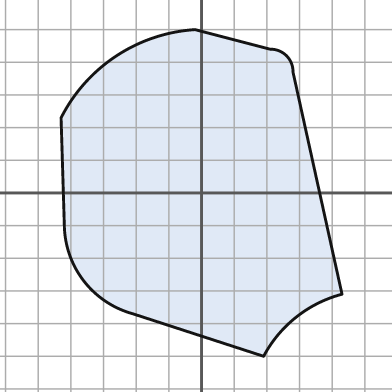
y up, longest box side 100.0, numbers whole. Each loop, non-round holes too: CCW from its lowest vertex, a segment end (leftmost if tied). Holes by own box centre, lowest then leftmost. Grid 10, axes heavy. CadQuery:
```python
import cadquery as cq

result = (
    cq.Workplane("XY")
    .moveTo(19.0, -50.0)
    .threePointArc((29.0, -38.0), (43.0, -31.0))
    .lineTo(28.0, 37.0)
    .threePointArc((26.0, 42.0), (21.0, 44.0))
    .lineTo(-2.0, 50.0)
    .threePointArc((-26.0, 42.0), (-43.0, 23.0))
    .lineTo(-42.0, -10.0)
    .threePointArc((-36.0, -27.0), (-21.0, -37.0))
    .close()
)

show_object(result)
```